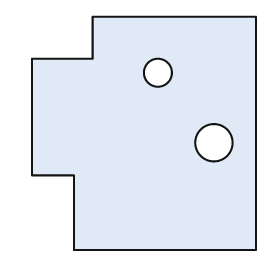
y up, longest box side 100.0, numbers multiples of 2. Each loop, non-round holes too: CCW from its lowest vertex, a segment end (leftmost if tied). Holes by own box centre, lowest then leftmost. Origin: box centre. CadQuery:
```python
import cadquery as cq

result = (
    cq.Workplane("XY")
    .moveTo(-30.0, -50.0)
    .lineTo(48.0, -50.0)
    .lineTo(48.0, 50.0)
    .lineTo(-22.0, 50.0)
    .lineTo(-22.0, 32.0)
    .lineTo(-48.0, 32.0)
    .lineTo(-48.0, -18.0)
    .lineTo(-30.0, -18.0)
    .close()
    .moveTo(30.0, -4.0)
    .circle(8.0)
    .moveTo(6.0, 26.0)
    .circle(6.0)
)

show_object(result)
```